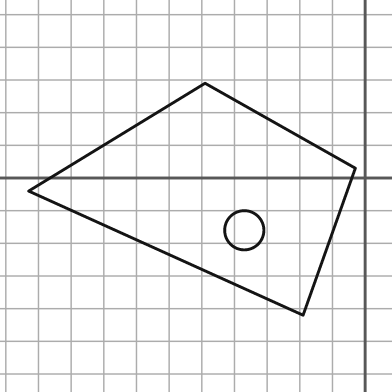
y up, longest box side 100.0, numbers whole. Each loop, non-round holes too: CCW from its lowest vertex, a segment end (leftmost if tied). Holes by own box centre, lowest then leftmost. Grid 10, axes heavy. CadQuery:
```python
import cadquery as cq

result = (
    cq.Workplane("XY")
    .moveTo(-19.0, -42.0)
    .lineTo(-3.0, 3.0)
    .lineTo(-49.0, 29.0)
    .lineTo(-103.0, -4.0)
    .close()
    .moveTo(-37.0, -16.0)
    .circle(6.0)
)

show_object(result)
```